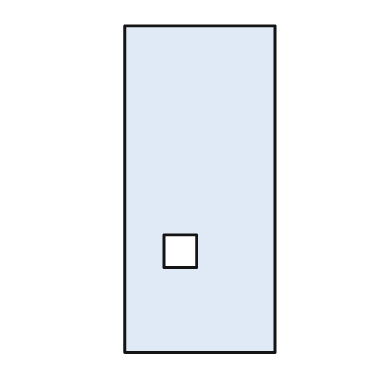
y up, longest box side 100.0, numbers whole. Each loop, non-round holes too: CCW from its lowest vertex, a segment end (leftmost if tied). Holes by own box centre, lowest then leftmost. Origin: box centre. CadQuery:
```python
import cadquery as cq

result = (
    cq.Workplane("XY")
    .moveTo(-23.0, -50.0)
    .lineTo(23.0, -50.0)
    .lineTo(23.0, 50.0)
    .lineTo(-23.0, 50.0)
    .close()
    .moveTo(-11.0, -24.0)
    .lineTo(-1.0, -24.0)
    .lineTo(-1.0, -14.0)
    .lineTo(-11.0, -14.0)
    .close()
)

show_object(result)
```